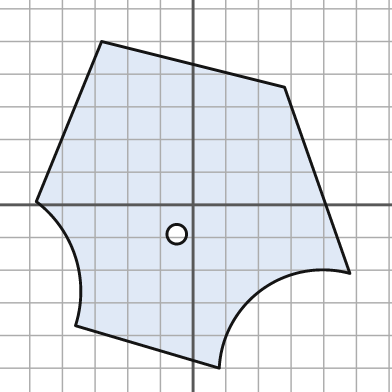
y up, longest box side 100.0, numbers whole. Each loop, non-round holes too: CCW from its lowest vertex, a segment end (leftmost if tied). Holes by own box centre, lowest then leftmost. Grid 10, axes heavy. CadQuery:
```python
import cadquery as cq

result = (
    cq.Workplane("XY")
    .moveTo(8.0, -50.0)
    .threePointArc((21.0, -26.0), (48.0, -21.0))
    .lineTo(28.0, 36.0)
    .lineTo(-28.0, 50.0)
    .lineTo(-48.0, 1.0)
    .threePointArc((-36.0, -16.0), (-36.0, -37.0))
    .close()
    .moveTo(-5.0, -9.0)
    .circle(3.0)
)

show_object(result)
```